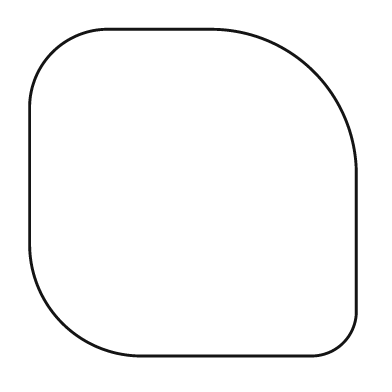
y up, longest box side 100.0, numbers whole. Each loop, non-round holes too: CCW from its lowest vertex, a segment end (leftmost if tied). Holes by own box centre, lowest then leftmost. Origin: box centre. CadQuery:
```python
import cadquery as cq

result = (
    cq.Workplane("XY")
    .moveTo(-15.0, -50.0)
    .lineTo(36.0, -50.0)
    .threePointArc((46.0, -46.0), (50.0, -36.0))
    .lineTo(50.0, 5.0)
    .threePointArc((37.0, 37.0), (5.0, 50.0))
    .lineTo(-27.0, 50.0)
    .threePointArc((-43.0, 43.0), (-50.0, 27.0))
    .lineTo(-50.0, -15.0)
    .threePointArc((-40.0, -40.0), (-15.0, -50.0))
    .close()
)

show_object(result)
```